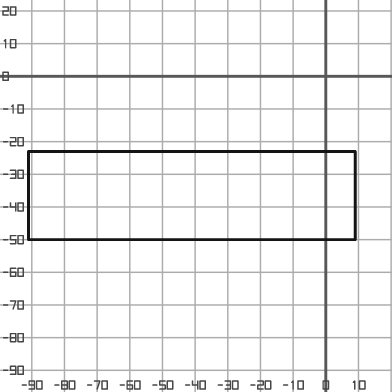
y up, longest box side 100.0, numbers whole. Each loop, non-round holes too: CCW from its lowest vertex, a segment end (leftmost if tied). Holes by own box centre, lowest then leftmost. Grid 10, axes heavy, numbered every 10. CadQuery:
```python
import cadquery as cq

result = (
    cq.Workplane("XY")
    .moveTo(-91.0, -50.0)
    .lineTo(9.0, -50.0)
    .lineTo(9.0, -23.0)
    .lineTo(-91.0, -23.0)
    .close()
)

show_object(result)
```